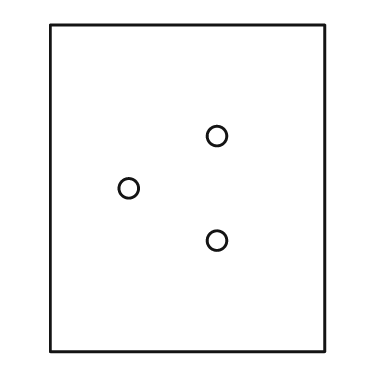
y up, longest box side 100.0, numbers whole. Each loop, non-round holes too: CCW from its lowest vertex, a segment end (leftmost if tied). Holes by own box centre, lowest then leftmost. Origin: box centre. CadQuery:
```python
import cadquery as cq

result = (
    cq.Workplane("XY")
    .moveTo(-42.0, -50.0)
    .lineTo(42.0, -50.0)
    .lineTo(42.0, 50.0)
    .lineTo(-42.0, 50.0)
    .close()
    .moveTo(9.0, -16.0)
    .circle(3.0)
    .moveTo(-18.0, 0.0)
    .circle(3.0)
    .moveTo(9.0, 16.0)
    .circle(3.0)
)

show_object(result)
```